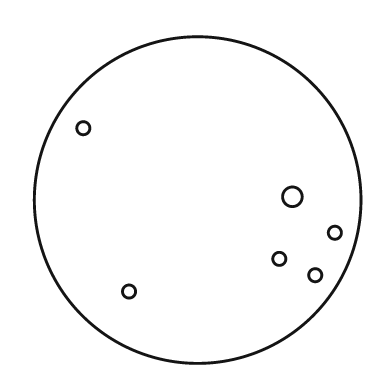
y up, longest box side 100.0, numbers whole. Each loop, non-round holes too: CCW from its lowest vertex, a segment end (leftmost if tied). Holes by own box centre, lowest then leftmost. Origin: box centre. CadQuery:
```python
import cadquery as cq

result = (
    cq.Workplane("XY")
    .moveTo(0.0, 0.0)
    .circle(50.0)
    .moveTo(-21.0, -28.0)
    .circle(2.0)
    .moveTo(36.0, -23.0)
    .circle(2.0)
    .moveTo(25.0, -18.0)
    .circle(2.0)
    .moveTo(42.0, -10.0)
    .circle(2.0)
    .moveTo(29.0, 1.0)
    .circle(3.0)
    .moveTo(-35.0, 22.0)
    .circle(2.0)
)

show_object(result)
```